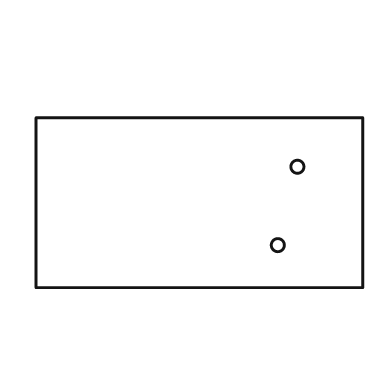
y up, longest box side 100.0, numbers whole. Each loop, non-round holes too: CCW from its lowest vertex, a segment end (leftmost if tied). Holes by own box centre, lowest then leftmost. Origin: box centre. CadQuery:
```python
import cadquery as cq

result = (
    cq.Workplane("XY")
    .moveTo(-50.0, -26.0)
    .lineTo(50.0, -26.0)
    .lineTo(50.0, 26.0)
    .lineTo(-50.0, 26.0)
    .close()
    .moveTo(24.0, -13.0)
    .circle(2.0)
    .moveTo(30.0, 11.0)
    .circle(2.0)
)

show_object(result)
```